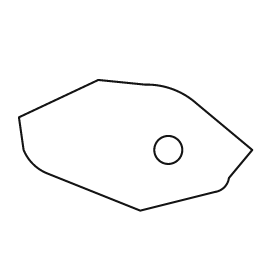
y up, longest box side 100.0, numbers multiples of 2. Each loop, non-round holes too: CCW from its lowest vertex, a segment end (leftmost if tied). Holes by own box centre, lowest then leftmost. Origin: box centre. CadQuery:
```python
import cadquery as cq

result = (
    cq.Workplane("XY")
    .moveTo(2.0, -28.0)
    .lineTo(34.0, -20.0)
    .threePointArc((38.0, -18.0), (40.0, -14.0))
    .lineTo(50.0, -2.0)
    .lineTo(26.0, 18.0)
    .threePointArc((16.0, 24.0), (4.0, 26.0))
    .lineTo(-16.0, 28.0)
    .lineTo(-50.0, 12.0)
    .lineTo(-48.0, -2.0)
    .threePointArc((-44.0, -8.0), (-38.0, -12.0))
    .close()
    .moveTo(14.0, -2.0)
    .circle(6.0)
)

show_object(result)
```